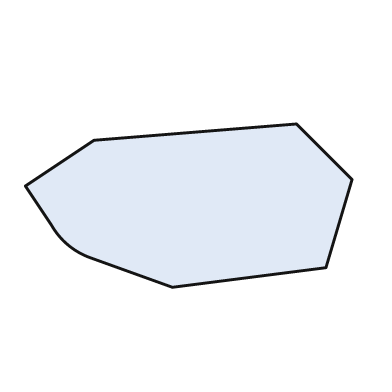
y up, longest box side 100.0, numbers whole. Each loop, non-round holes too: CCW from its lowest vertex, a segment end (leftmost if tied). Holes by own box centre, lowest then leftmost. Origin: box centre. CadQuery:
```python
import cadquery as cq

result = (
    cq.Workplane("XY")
    .moveTo(-5.0, -25.0)
    .lineTo(42.0, -19.0)
    .lineTo(50.0, 8.0)
    .lineTo(33.0, 25.0)
    .lineTo(-29.0, 20.0)
    .lineTo(-50.0, 6.0)
    .lineTo(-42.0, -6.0)
    .threePointArc((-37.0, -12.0), (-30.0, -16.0))
    .close()
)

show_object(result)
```